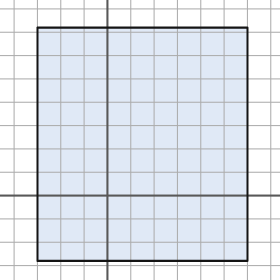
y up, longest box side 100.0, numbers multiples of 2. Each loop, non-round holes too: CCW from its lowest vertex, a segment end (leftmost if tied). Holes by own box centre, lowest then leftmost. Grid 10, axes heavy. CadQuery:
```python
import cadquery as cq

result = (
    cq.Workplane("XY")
    .moveTo(-30.0, -28.0)
    .lineTo(60.0, -28.0)
    .lineTo(60.0, 72.0)
    .lineTo(-30.0, 72.0)
    .close()
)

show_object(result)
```